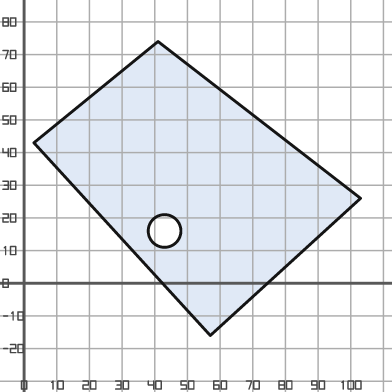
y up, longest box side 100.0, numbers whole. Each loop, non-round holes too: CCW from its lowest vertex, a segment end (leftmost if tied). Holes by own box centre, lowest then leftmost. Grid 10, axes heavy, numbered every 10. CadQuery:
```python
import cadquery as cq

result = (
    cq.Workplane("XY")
    .moveTo(57.0, -16.0)
    .lineTo(103.0, 26.0)
    .lineTo(41.0, 74.0)
    .lineTo(3.0, 43.0)
    .close()
    .moveTo(43.0, 16.0)
    .circle(5.0)
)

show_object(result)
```